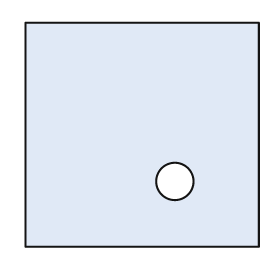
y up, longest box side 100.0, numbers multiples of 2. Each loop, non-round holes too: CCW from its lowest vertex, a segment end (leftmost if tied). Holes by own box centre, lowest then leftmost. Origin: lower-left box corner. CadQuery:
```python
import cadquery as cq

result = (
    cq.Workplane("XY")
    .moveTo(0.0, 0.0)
    .lineTo(100.0, 0.0)
    .lineTo(100.0, 96.0)
    .lineTo(0.0, 96.0)
    .close()
    .moveTo(64.0, 28.0)
    .circle(8.0)
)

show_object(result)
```